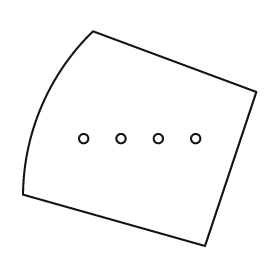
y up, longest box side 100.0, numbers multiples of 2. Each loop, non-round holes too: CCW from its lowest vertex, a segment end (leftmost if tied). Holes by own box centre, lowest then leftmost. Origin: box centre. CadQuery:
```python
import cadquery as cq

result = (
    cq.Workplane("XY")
    .moveTo(28.0, -46.0)
    .lineTo(50.0, 20.0)
    .lineTo(-20.0, 46.0)
    .threePointArc((-42.0, 14.0), (-50.0, -24.0))
    .close()
    .moveTo(-24.0, 0.0)
    .circle(2.0)
    .moveTo(-8.0, 0.0)
    .circle(2.0)
    .moveTo(8.0, 0.0)
    .circle(2.0)
    .moveTo(24.0, 0.0)
    .circle(2.0)
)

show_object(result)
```